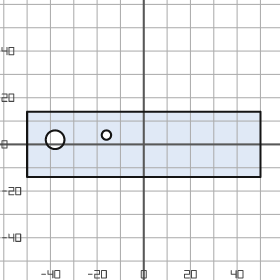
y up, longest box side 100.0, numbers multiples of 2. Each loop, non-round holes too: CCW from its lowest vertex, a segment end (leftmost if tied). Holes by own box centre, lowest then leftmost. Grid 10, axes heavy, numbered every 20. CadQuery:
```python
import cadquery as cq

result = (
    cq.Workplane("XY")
    .moveTo(-50.0, -14.0)
    .lineTo(50.0, -14.0)
    .lineTo(50.0, 14.0)
    .lineTo(-50.0, 14.0)
    .close()
    .moveTo(-38.0, 2.0)
    .circle(4.0)
    .moveTo(-16.0, 4.0)
    .circle(2.0)
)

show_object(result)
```